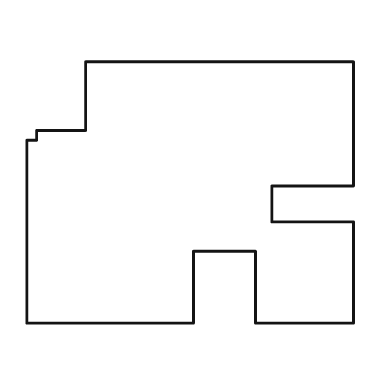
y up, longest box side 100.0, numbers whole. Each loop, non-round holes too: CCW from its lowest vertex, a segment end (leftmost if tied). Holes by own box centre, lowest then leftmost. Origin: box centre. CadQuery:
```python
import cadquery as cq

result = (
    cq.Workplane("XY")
    .moveTo(-50.0, -40.0)
    .lineTo(1.0, -40.0)
    .lineTo(1.0, -18.0)
    .lineTo(20.0, -18.0)
    .lineTo(20.0, -40.0)
    .lineTo(50.0, -40.0)
    .lineTo(50.0, -9.0)
    .lineTo(25.0, -9.0)
    .lineTo(25.0, 2.0)
    .lineTo(50.0, 2.0)
    .lineTo(50.0, 40.0)
    .lineTo(-32.0, 40.0)
    .lineTo(-32.0, 19.0)
    .lineTo(-47.0, 19.0)
    .lineTo(-47.0, 16.0)
    .lineTo(-50.0, 16.0)
    .close()
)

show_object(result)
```